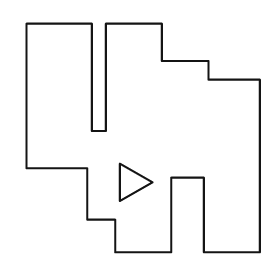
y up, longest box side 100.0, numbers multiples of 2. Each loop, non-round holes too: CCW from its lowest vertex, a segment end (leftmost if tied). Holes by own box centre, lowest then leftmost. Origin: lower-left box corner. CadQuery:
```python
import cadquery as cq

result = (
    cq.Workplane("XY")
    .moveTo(38.0, 0.0)
    .lineTo(62.0, 0.0)
    .lineTo(62.0, 32.0)
    .lineTo(76.0, 32.0)
    .lineTo(76.0, 0.0)
    .lineTo(100.0, 0.0)
    .lineTo(100.0, 74.0)
    .lineTo(78.0, 74.0)
    .lineTo(78.0, 82.0)
    .lineTo(58.0, 82.0)
    .lineTo(58.0, 98.0)
    .lineTo(34.0, 98.0)
    .lineTo(34.0, 52.0)
    .lineTo(28.0, 52.0)
    .lineTo(28.0, 98.0)
    .lineTo(0.0, 98.0)
    .lineTo(0.0, 36.0)
    .lineTo(26.0, 36.0)
    .lineTo(26.0, 14.0)
    .lineTo(38.0, 14.0)
    .close()
    .moveTo(40.0, 22.0)
    .lineTo(54.0, 30.0)
    .lineTo(40.0, 38.0)
    .close()
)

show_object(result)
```